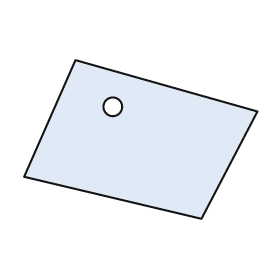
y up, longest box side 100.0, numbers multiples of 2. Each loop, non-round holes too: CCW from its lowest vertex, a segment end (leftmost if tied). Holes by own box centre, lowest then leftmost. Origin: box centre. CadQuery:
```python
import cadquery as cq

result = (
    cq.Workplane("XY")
    .moveTo(26.0, -34.0)
    .lineTo(50.0, 12.0)
    .lineTo(-28.0, 34.0)
    .lineTo(-50.0, -16.0)
    .close()
    .moveTo(-12.0, 14.0)
    .circle(4.0)
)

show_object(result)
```